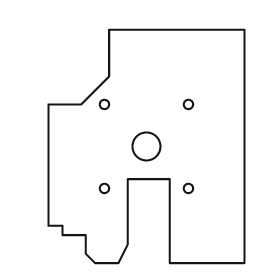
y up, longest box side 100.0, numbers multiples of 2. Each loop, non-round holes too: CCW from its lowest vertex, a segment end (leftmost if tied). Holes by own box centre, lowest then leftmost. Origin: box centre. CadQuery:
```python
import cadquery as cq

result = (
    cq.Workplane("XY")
    .moveTo(-22.0, -50.0)
    .lineTo(-12.0, -50.0)
    .lineTo(-8.0, -42.0)
    .lineTo(-8.0, -14.0)
    .lineTo(10.0, -14.0)
    .lineTo(10.0, -50.0)
    .lineTo(42.0, -50.0)
    .lineTo(42.0, 50.0)
    .lineTo(-16.0, 50.0)
    .lineTo(-16.0, 30.0)
    .lineTo(-28.0, 18.0)
    .lineTo(-42.0, 18.0)
    .lineTo(-42.0, -34.0)
    .lineTo(-36.0, -34.0)
    .lineTo(-36.0, -38.0)
    .lineTo(-26.0, -38.0)
    .lineTo(-26.0, -46.0)
    .close()
    .moveTo(-18.0, -18.0)
    .circle(2.0)
    .moveTo(18.0, -18.0)
    .circle(2.0)
    .moveTo(0.0, 0.0)
    .circle(6.0)
    .moveTo(-18.0, 18.0)
    .circle(2.0)
    .moveTo(18.0, 18.0)
    .circle(2.0)
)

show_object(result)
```